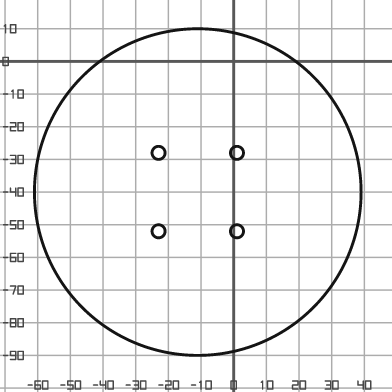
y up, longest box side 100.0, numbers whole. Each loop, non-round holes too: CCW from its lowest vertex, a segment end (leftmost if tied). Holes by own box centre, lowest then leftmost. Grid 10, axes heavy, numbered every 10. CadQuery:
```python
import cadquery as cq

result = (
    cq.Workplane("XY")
    .moveTo(-11.0, -40.0)
    .circle(50.0)
    .moveTo(-23.0, -52.0)
    .circle(2.0)
    .moveTo(1.0, -52.0)
    .circle(2.0)
    .moveTo(-23.0, -28.0)
    .circle(2.0)
    .moveTo(1.0, -28.0)
    .circle(2.0)
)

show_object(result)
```